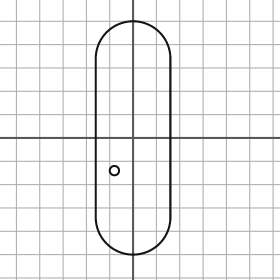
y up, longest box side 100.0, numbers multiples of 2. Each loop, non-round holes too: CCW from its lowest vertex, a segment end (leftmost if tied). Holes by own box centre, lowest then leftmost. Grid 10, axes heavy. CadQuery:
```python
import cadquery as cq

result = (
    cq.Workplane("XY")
    .moveTo(-16.0, -34.0)
    .threePointArc((0.0, -50.0), (16.0, -34.0))
    .lineTo(16.0, 34.0)
    .threePointArc((0.0, 50.0), (-16.0, 34.0))
    .close()
    .moveTo(-8.0, -14.0)
    .circle(2.0)
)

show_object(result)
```